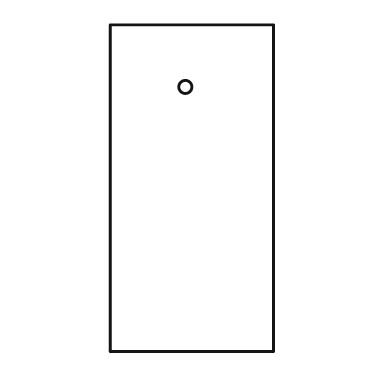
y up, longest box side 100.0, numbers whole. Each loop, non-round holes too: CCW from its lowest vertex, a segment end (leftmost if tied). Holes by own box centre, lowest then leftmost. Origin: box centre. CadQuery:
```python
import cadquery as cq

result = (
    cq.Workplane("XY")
    .moveTo(-25.0, -50.0)
    .lineTo(25.0, -50.0)
    .lineTo(25.0, 50.0)
    .lineTo(-25.0, 50.0)
    .close()
    .moveTo(-2.0, 31.0)
    .circle(2.0)
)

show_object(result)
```